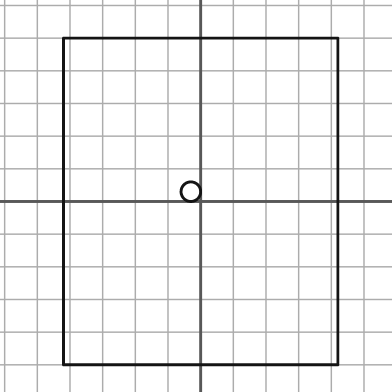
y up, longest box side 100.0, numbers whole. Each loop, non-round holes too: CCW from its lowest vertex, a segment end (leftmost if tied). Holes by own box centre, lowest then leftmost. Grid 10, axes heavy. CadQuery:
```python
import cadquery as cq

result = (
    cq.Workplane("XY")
    .moveTo(-42.0, -50.0)
    .lineTo(42.0, -50.0)
    .lineTo(42.0, 50.0)
    .lineTo(-42.0, 50.0)
    .close()
    .moveTo(-3.0, 3.0)
    .circle(3.0)
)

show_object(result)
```